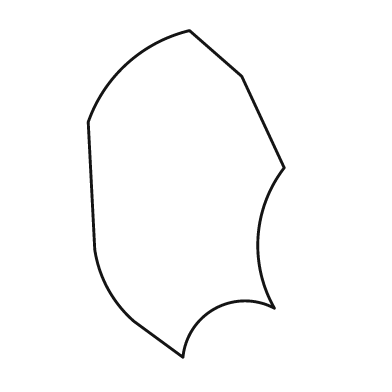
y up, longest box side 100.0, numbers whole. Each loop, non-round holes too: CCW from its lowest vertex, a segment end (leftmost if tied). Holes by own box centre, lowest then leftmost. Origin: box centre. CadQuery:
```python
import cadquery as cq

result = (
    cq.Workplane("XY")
    .moveTo(-1.0, -50.0)
    .threePointArc((9.0, -35.0), (27.0, -35.0))
    .threePointArc((22.0, -13.0), (30.0, 8.0))
    .lineTo(17.0, 36.0)
    .lineTo(1.0, 50.0)
    .threePointArc((-18.0, 40.0), (-30.0, 22.0))
    .lineTo(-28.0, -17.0)
    .threePointArc((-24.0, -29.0), (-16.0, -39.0))
    .close()
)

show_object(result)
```